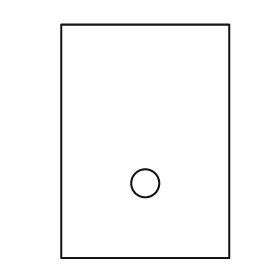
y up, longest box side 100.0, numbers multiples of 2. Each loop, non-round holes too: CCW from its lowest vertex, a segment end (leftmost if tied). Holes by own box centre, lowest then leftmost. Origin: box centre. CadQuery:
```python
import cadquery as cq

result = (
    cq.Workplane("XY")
    .moveTo(-36.0, -50.0)
    .lineTo(36.0, -50.0)
    .lineTo(36.0, 50.0)
    .lineTo(-36.0, 50.0)
    .close()
    .moveTo(0.0, -18.0)
    .circle(6.0)
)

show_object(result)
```